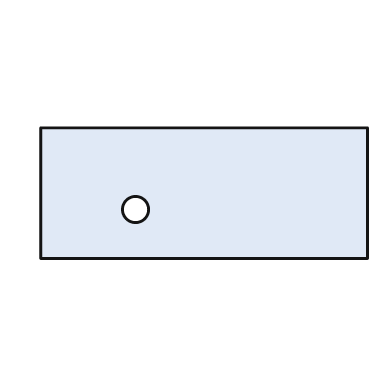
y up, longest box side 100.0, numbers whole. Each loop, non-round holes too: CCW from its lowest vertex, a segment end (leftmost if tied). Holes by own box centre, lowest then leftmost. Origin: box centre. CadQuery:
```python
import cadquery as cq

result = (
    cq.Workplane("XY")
    .moveTo(-50.0, -20.0)
    .lineTo(50.0, -20.0)
    .lineTo(50.0, 20.0)
    .lineTo(-50.0, 20.0)
    .close()
    .moveTo(-21.0, -5.0)
    .circle(4.0)
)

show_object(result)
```